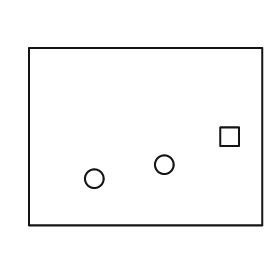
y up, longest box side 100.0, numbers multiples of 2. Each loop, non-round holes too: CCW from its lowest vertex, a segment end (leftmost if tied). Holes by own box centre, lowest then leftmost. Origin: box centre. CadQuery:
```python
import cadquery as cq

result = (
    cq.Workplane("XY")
    .moveTo(-50.0, -38.0)
    .lineTo(50.0, -38.0)
    .lineTo(50.0, 38.0)
    .lineTo(-50.0, 38.0)
    .close()
    .moveTo(-22.0, -18.0)
    .circle(4.0)
    .moveTo(8.0, -12.0)
    .circle(4.0)
    .moveTo(32.0, -4.0)
    .lineTo(40.0, -4.0)
    .lineTo(40.0, 4.0)
    .lineTo(32.0, 4.0)
    .close()
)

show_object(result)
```